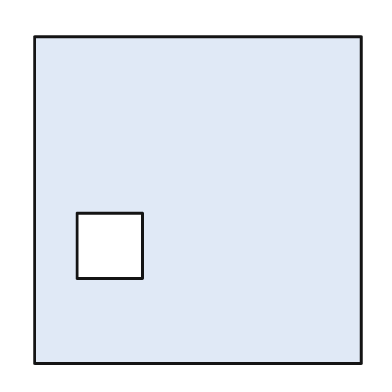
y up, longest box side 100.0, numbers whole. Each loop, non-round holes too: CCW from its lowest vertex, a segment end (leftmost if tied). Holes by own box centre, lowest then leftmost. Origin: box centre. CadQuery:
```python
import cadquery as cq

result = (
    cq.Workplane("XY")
    .moveTo(-50.0, -50.0)
    .lineTo(50.0, -50.0)
    .lineTo(50.0, 50.0)
    .lineTo(-50.0, 50.0)
    .close()
    .moveTo(-37.0, -24.0)
    .lineTo(-17.0, -24.0)
    .lineTo(-17.0, -4.0)
    .lineTo(-37.0, -4.0)
    .close()
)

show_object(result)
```